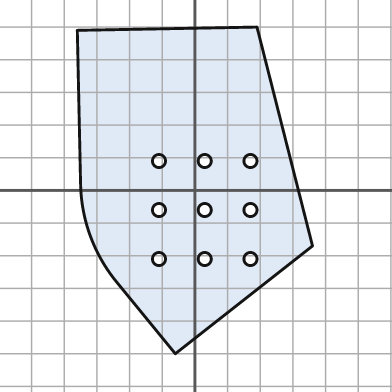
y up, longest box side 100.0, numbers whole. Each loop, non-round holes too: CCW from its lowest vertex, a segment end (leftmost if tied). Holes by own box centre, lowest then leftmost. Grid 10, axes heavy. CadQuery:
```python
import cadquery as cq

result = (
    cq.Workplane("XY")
    .moveTo(-6.0, -50.0)
    .lineTo(36.0, -17.0)
    .lineTo(19.0, 50.0)
    .lineTo(-36.0, 49.0)
    .lineTo(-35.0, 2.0)
    .threePointArc((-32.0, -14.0), (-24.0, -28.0))
    .close()
    .moveTo(-11.0, -21.0)
    .circle(2.0)
    .moveTo(3.0, -21.0)
    .circle(2.0)
    .moveTo(17.0, -21.0)
    .circle(2.0)
    .moveTo(-11.0, -6.0)
    .circle(2.0)
    .moveTo(3.0, -6.0)
    .circle(2.0)
    .moveTo(17.0, -6.0)
    .circle(2.0)
    .moveTo(-11.0, 9.0)
    .circle(2.0)
    .moveTo(3.0, 9.0)
    .circle(2.0)
    .moveTo(17.0, 9.0)
    .circle(2.0)
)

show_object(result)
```